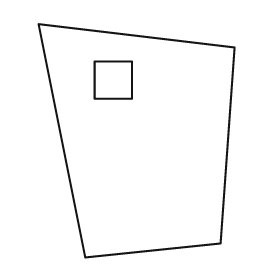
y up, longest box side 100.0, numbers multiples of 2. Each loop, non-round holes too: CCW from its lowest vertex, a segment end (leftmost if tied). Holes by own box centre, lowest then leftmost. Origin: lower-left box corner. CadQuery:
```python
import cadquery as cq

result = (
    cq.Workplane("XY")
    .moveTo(20.0, 0.0)
    .lineTo(78.0, 6.0)
    .lineTo(84.0, 90.0)
    .lineTo(0.0, 100.0)
    .close()
    .moveTo(24.0, 68.0)
    .lineTo(40.0, 68.0)
    .lineTo(40.0, 84.0)
    .lineTo(24.0, 84.0)
    .close()
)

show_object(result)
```